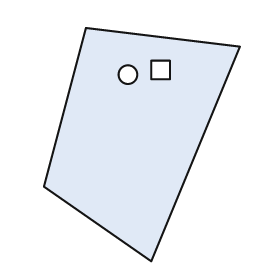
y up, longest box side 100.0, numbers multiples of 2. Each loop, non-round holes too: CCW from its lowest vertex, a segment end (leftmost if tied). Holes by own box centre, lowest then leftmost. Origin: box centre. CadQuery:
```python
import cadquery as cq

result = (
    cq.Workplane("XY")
    .moveTo(4.0, -50.0)
    .lineTo(42.0, 42.0)
    .lineTo(-24.0, 50.0)
    .lineTo(-42.0, -18.0)
    .close()
    .moveTo(-6.0, 30.0)
    .circle(4.0)
    .moveTo(4.0, 28.0)
    .lineTo(12.0, 28.0)
    .lineTo(12.0, 36.0)
    .lineTo(4.0, 36.0)
    .close()
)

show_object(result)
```